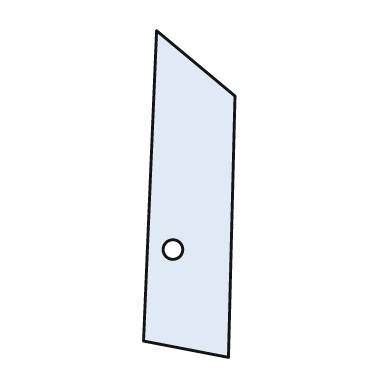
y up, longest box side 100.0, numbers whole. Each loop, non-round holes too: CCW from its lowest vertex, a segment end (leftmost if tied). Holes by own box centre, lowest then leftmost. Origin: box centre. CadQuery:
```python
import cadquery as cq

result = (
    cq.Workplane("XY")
    .moveTo(12.0, -50.0)
    .lineTo(14.0, 30.0)
    .lineTo(-10.0, 50.0)
    .lineTo(-14.0, -45.0)
    .close()
    .moveTo(-5.0, -17.0)
    .circle(3.0)
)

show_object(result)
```